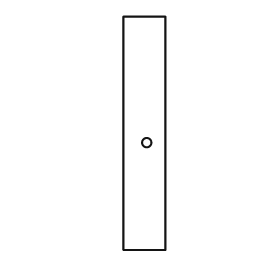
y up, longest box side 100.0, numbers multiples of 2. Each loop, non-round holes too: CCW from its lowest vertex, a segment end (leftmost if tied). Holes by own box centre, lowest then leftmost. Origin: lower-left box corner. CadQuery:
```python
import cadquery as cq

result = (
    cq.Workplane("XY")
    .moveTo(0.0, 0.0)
    .lineTo(18.0, 0.0)
    .lineTo(18.0, 100.0)
    .lineTo(0.0, 100.0)
    .close()
    .moveTo(10.0, 46.0)
    .circle(2.0)
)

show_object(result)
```